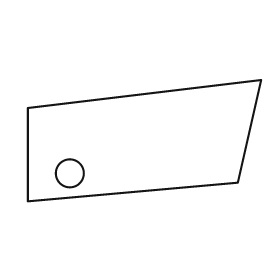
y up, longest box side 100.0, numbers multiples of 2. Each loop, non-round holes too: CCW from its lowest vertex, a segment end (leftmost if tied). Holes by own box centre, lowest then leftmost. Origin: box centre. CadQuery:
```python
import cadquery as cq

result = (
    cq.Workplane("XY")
    .moveTo(-50.0, -26.0)
    .lineTo(40.0, -18.0)
    .lineTo(50.0, 26.0)
    .lineTo(-50.0, 14.0)
    .close()
    .moveTo(-32.0, -14.0)
    .circle(6.0)
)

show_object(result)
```